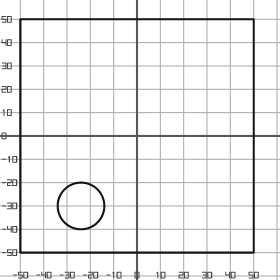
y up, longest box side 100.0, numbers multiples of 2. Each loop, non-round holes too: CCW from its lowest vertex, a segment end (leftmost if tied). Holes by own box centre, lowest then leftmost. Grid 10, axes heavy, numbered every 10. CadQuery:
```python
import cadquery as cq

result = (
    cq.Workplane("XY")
    .moveTo(-50.0, -50.0)
    .lineTo(50.0, -50.0)
    .lineTo(50.0, 50.0)
    .lineTo(-50.0, 50.0)
    .close()
    .moveTo(-24.0, -30.0)
    .circle(10.0)
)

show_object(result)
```